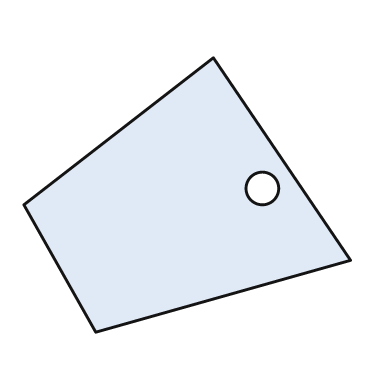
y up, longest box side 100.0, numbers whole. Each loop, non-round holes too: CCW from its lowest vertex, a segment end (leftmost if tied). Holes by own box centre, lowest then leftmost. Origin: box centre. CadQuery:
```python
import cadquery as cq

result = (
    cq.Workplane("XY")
    .moveTo(-28.0, -42.0)
    .lineTo(50.0, -20.0)
    .lineTo(8.0, 42.0)
    .lineTo(-50.0, -3.0)
    .close()
    .moveTo(23.0, 2.0)
    .circle(5.0)
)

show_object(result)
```